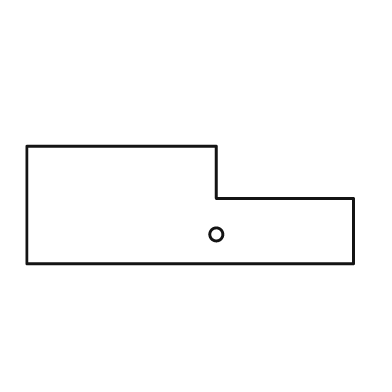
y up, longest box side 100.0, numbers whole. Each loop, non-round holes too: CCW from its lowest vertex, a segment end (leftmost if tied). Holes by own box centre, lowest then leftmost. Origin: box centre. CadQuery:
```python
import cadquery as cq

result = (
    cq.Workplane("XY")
    .moveTo(-50.0, -18.0)
    .lineTo(50.0, -18.0)
    .lineTo(50.0, 2.0)
    .lineTo(8.0, 2.0)
    .lineTo(8.0, 18.0)
    .lineTo(-50.0, 18.0)
    .close()
    .moveTo(8.0, -9.0)
    .circle(2.0)
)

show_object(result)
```